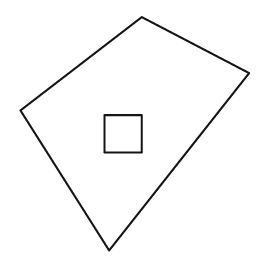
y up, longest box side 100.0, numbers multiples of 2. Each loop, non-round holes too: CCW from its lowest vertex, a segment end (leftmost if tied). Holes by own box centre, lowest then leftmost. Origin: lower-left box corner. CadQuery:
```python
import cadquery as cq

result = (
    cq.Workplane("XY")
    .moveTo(38.0, 0.0)
    .lineTo(98.0, 76.0)
    .lineTo(52.0, 100.0)
    .lineTo(0.0, 60.0)
    .close()
    .moveTo(36.0, 42.0)
    .lineTo(52.0, 42.0)
    .lineTo(52.0, 58.0)
    .lineTo(36.0, 58.0)
    .close()
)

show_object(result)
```